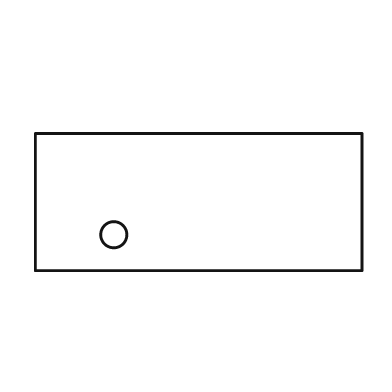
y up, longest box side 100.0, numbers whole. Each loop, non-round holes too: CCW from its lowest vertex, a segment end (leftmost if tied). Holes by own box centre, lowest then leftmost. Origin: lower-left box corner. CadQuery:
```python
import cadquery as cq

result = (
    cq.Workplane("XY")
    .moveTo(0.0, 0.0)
    .lineTo(100.0, 0.0)
    .lineTo(100.0, 42.0)
    .lineTo(0.0, 42.0)
    .close()
    .moveTo(24.0, 11.0)
    .circle(4.0)
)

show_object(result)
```